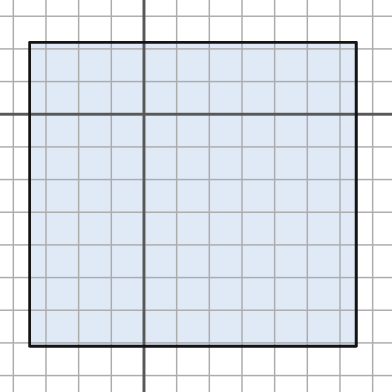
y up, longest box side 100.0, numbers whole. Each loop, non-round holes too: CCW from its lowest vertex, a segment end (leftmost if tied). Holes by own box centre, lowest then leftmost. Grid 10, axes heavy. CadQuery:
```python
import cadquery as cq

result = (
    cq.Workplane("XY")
    .moveTo(-35.0, -71.0)
    .lineTo(65.0, -71.0)
    .lineTo(65.0, 22.0)
    .lineTo(-35.0, 22.0)
    .close()
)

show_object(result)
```